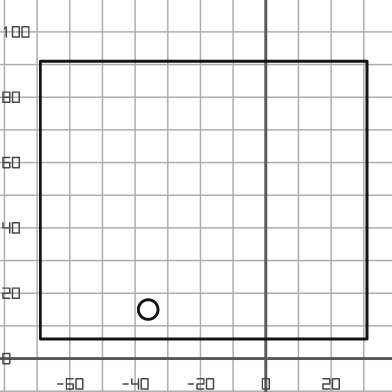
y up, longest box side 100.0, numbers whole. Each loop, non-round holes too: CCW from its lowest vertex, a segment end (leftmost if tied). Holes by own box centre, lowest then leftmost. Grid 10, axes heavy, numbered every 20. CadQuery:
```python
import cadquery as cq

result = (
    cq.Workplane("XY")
    .moveTo(-69.0, 6.0)
    .lineTo(31.0, 6.0)
    .lineTo(31.0, 91.0)
    .lineTo(-69.0, 91.0)
    .close()
    .moveTo(-36.0, 15.0)
    .circle(3.0)
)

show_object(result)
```